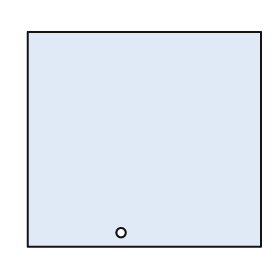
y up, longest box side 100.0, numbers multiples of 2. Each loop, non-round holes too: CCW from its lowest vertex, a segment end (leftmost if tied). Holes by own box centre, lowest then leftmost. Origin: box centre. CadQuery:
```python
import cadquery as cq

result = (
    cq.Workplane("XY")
    .moveTo(-50.0, -46.0)
    .lineTo(50.0, -46.0)
    .lineTo(50.0, 46.0)
    .lineTo(-50.0, 46.0)
    .close()
    .moveTo(-10.0, -40.0)
    .circle(2.0)
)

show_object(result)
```